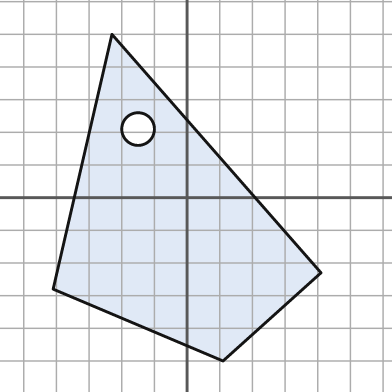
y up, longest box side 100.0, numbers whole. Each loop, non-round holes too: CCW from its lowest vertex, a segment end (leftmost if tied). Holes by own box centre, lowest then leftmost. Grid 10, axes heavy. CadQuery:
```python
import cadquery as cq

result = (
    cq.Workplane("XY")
    .moveTo(11.0, -50.0)
    .lineTo(41.0, -23.0)
    .lineTo(-23.0, 50.0)
    .lineTo(-41.0, -28.0)
    .close()
    .moveTo(-15.0, 21.0)
    .circle(5.0)
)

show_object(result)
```